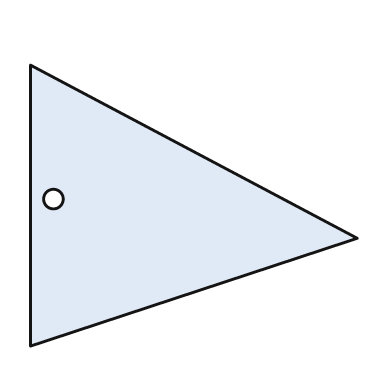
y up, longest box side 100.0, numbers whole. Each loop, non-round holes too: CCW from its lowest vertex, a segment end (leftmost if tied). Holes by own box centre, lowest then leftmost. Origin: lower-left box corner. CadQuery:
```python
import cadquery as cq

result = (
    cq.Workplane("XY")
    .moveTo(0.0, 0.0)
    .lineTo(100.0, 33.0)
    .lineTo(0.0, 86.0)
    .close()
    .moveTo(7.0, 45.0)
    .circle(3.0)
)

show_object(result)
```